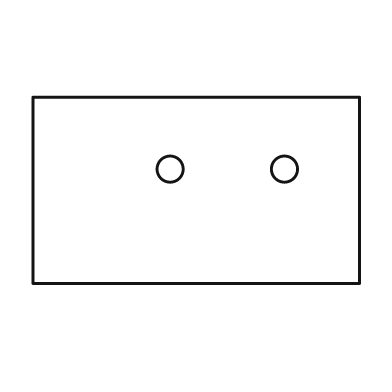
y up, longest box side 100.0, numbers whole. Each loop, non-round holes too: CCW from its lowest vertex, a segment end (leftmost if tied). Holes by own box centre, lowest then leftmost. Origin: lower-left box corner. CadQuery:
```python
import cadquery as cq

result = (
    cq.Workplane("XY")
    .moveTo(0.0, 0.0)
    .lineTo(100.0, 0.0)
    .lineTo(100.0, 57.0)
    .lineTo(0.0, 57.0)
    .close()
    .moveTo(42.0, 35.0)
    .circle(4.0)
    .moveTo(77.0, 35.0)
    .circle(4.0)
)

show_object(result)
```